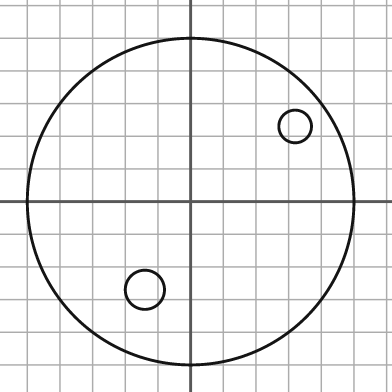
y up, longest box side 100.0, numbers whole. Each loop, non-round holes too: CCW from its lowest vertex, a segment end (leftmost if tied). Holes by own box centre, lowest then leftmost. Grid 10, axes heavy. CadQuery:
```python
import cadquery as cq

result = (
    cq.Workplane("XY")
    .moveTo(0.0, 0.0)
    .circle(50.0)
    .moveTo(-14.0, -27.0)
    .circle(6.0)
    .moveTo(32.0, 23.0)
    .circle(5.0)
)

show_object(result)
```